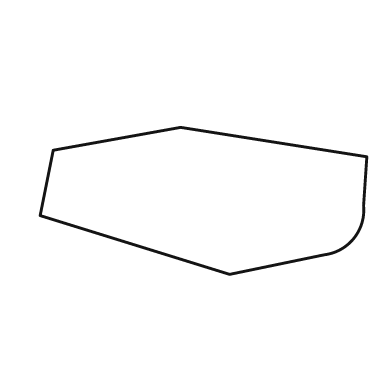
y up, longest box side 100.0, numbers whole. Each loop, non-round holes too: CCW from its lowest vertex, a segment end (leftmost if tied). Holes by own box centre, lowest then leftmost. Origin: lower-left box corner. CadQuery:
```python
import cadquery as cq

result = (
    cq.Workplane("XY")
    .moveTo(58.0, 0.0)
    .lineTo(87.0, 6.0)
    .threePointArc((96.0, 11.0), (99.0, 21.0))
    .lineTo(100.0, 36.0)
    .lineTo(43.0, 45.0)
    .lineTo(4.0, 38.0)
    .lineTo(0.0, 18.0)
    .close()
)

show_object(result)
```